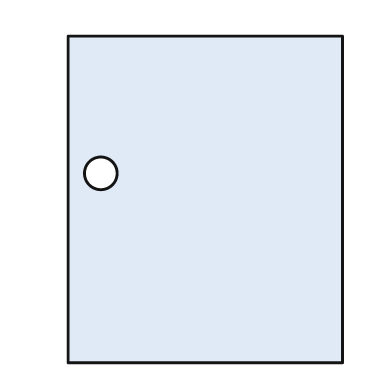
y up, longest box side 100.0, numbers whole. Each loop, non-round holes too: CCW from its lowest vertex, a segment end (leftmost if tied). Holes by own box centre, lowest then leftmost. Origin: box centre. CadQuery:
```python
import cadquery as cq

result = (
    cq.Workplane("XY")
    .moveTo(-42.0, -50.0)
    .lineTo(42.0, -50.0)
    .lineTo(42.0, 50.0)
    .lineTo(-42.0, 50.0)
    .close()
    .moveTo(-32.0, 8.0)
    .circle(5.0)
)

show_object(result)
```